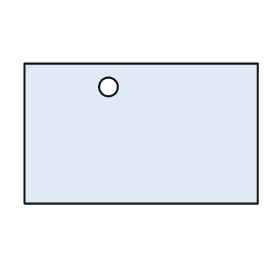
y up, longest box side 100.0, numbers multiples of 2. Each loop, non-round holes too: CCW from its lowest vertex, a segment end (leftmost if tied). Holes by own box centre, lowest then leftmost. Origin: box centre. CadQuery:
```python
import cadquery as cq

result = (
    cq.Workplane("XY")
    .moveTo(-50.0, -30.0)
    .lineTo(50.0, -30.0)
    .lineTo(50.0, 30.0)
    .lineTo(-50.0, 30.0)
    .close()
    .moveTo(-14.0, 20.0)
    .circle(4.0)
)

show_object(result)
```